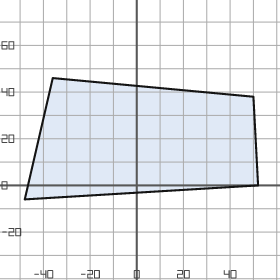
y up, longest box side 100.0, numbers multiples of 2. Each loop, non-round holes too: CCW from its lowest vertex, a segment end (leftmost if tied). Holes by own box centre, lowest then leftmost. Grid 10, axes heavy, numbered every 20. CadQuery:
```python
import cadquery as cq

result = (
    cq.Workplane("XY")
    .moveTo(-48.0, -6.0)
    .lineTo(52.0, 0.0)
    .lineTo(50.0, 38.0)
    .lineTo(-36.0, 46.0)
    .close()
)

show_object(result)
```